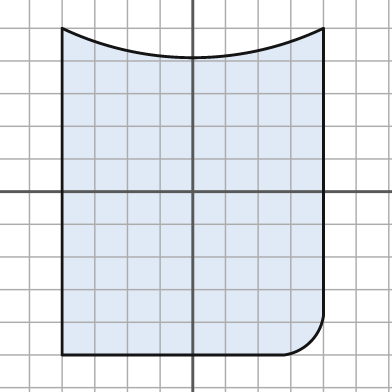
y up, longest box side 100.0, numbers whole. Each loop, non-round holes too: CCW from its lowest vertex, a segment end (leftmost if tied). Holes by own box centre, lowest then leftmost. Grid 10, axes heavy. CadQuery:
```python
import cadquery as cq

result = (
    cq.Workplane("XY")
    .moveTo(-40.0, -50.0)
    .lineTo(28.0, -50.0)
    .threePointArc((36.0, -46.0), (40.0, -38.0))
    .lineTo(40.0, 50.0)
    .threePointArc((0.0, 41.0), (-40.0, 50.0))
    .close()
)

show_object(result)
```